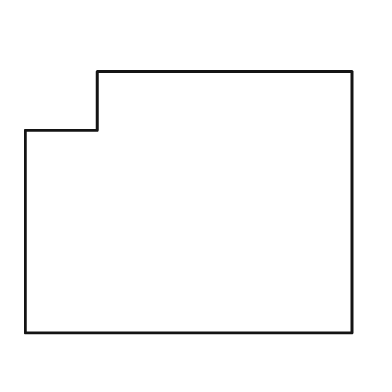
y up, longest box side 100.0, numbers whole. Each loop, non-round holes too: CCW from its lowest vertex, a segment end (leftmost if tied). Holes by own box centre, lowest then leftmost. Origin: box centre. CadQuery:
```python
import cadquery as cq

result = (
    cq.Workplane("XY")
    .moveTo(-50.0, -40.0)
    .lineTo(50.0, -40.0)
    .lineTo(50.0, 40.0)
    .lineTo(-28.0, 40.0)
    .lineTo(-28.0, 22.0)
    .lineTo(-50.0, 22.0)
    .close()
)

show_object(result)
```